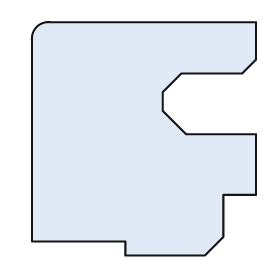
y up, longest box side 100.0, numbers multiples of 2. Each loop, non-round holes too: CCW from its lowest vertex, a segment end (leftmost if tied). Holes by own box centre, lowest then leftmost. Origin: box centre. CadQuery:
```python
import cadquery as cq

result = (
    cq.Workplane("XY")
    .moveTo(-8.0, -50.0)
    .lineTo(26.0, -50.0)
    .lineTo(34.0, -42.0)
    .lineTo(34.0, -24.0)
    .lineTo(48.0, -24.0)
    .lineTo(48.0, 2.0)
    .lineTo(18.0, 2.0)
    .lineTo(8.0, 12.0)
    .lineTo(8.0, 20.0)
    .lineTo(16.0, 28.0)
    .lineTo(42.0, 28.0)
    .lineTo(48.0, 34.0)
    .lineTo(48.0, 50.0)
    .lineTo(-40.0, 50.0)
    .threePointArc((-46.0, 48.0), (-48.0, 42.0))
    .lineTo(-48.0, -44.0)
    .lineTo(-8.0, -44.0)
    .close()
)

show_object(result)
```